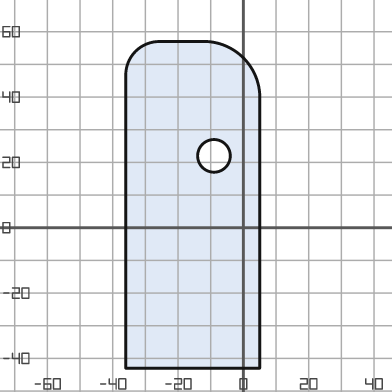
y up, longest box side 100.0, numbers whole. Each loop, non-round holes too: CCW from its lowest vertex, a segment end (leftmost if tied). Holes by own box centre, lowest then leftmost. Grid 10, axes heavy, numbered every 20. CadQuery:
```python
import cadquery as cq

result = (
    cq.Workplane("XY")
    .moveTo(-36.0, -43.0)
    .lineTo(5.0, -43.0)
    .lineTo(5.0, 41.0)
    .threePointArc((0.0, 52.0), (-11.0, 57.0))
    .lineTo(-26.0, 57.0)
    .threePointArc((-33.0, 54.0), (-36.0, 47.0))
    .close()
    .moveTo(-9.0, 22.0)
    .circle(5.0)
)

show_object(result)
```